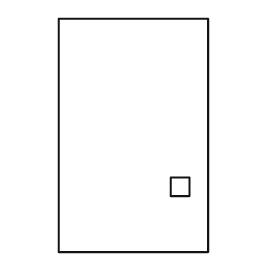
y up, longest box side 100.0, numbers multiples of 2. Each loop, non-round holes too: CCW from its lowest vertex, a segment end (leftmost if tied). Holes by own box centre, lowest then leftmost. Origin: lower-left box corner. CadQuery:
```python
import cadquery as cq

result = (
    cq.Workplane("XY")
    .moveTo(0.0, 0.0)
    .lineTo(64.0, 0.0)
    .lineTo(64.0, 100.0)
    .lineTo(0.0, 100.0)
    .close()
    .moveTo(48.0, 24.0)
    .lineTo(56.0, 24.0)
    .lineTo(56.0, 32.0)
    .lineTo(48.0, 32.0)
    .close()
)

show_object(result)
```